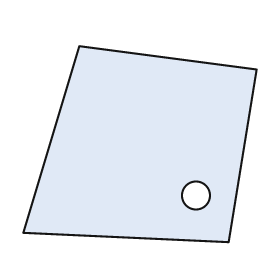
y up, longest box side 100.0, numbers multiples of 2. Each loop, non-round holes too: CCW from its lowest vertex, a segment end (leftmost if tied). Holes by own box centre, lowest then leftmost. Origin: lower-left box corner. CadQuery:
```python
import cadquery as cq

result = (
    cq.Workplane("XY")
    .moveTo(88.0, 0.0)
    .lineTo(100.0, 74.0)
    .lineTo(24.0, 84.0)
    .lineTo(0.0, 4.0)
    .close()
    .moveTo(74.0, 20.0)
    .circle(6.0)
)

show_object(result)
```